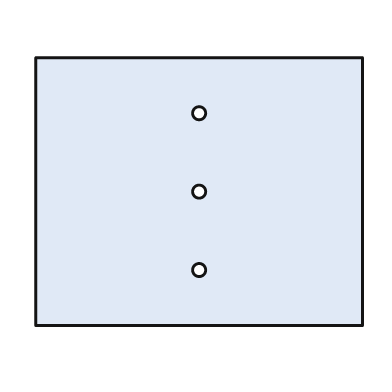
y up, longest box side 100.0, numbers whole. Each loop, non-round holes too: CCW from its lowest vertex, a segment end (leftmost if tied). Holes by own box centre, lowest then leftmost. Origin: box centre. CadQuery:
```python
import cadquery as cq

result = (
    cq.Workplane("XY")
    .moveTo(-50.0, -41.0)
    .lineTo(50.0, -41.0)
    .lineTo(50.0, 41.0)
    .lineTo(-50.0, 41.0)
    .close()
    .moveTo(0.0, -24.0)
    .circle(2.0)
    .moveTo(0.0, 0.0)
    .circle(2.0)
    .moveTo(0.0, 24.0)
    .circle(2.0)
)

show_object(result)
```